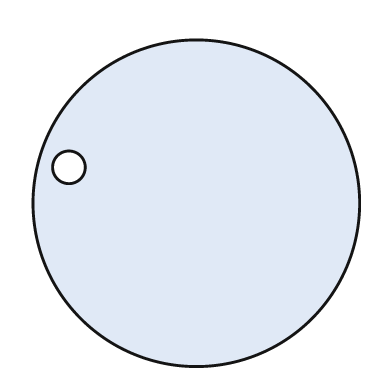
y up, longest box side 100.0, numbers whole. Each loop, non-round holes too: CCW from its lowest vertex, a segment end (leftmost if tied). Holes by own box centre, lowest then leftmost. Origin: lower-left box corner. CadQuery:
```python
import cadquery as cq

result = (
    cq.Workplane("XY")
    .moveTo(50.0, 50.0)
    .circle(50.0)
    .moveTo(11.0, 61.0)
    .circle(5.0)
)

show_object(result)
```